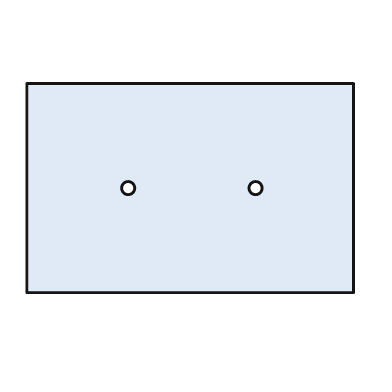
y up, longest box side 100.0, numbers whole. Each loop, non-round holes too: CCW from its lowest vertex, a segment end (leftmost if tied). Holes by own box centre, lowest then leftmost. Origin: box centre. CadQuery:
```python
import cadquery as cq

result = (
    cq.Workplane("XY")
    .moveTo(-50.0, -32.0)
    .lineTo(50.0, -32.0)
    .lineTo(50.0, 32.0)
    .lineTo(-50.0, 32.0)
    .close()
    .moveTo(-19.0, 0.0)
    .circle(2.0)
    .moveTo(20.0, 0.0)
    .circle(2.0)
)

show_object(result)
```